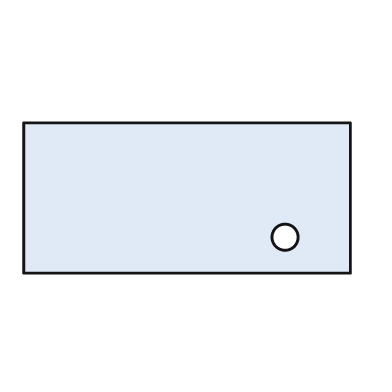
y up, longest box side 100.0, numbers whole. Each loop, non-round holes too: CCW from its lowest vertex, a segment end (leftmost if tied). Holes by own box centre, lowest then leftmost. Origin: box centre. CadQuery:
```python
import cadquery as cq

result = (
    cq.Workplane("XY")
    .moveTo(-50.0, -23.0)
    .lineTo(50.0, -23.0)
    .lineTo(50.0, 23.0)
    .lineTo(-50.0, 23.0)
    .close()
    .moveTo(30.0, -12.0)
    .circle(4.0)
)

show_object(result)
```